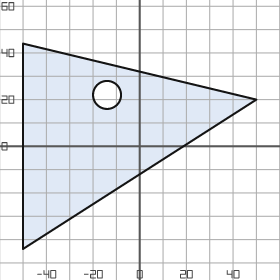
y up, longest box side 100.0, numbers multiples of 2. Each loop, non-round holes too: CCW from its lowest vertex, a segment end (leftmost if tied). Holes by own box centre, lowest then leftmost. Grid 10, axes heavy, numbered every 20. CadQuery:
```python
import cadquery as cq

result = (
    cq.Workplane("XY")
    .moveTo(-50.0, -44.0)
    .lineTo(50.0, 20.0)
    .lineTo(-50.0, 44.0)
    .close()
    .moveTo(-14.0, 22.0)
    .circle(6.0)
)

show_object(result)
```